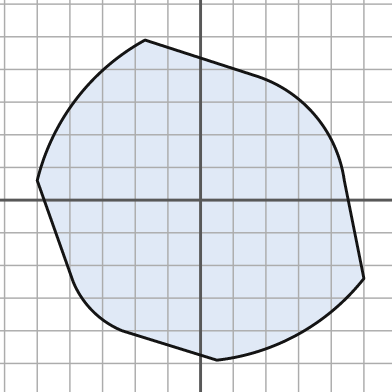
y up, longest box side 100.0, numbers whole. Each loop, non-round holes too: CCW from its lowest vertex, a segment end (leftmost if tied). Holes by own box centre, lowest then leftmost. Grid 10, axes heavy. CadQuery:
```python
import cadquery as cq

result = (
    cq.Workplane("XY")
    .moveTo(5.0, -49.0)
    .threePointArc((30.0, -41.0), (50.0, -24.0))
    .lineTo(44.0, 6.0)
    .threePointArc((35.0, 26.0), (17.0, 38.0))
    .lineTo(-17.0, 49.0)
    .threePointArc((-38.0, 31.0), (-50.0, 6.0))
    .lineTo(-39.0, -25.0)
    .threePointArc((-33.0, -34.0), (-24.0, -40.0))
    .close()
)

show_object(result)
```